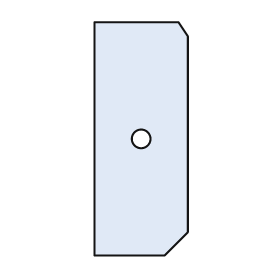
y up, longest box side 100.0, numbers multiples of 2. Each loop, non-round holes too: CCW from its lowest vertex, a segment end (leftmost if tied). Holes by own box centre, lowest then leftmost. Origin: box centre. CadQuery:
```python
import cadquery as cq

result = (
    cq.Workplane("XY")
    .moveTo(-20.0, -50.0)
    .lineTo(10.0, -50.0)
    .lineTo(20.0, -40.0)
    .lineTo(20.0, 44.0)
    .lineTo(16.0, 50.0)
    .lineTo(-20.0, 50.0)
    .close()
    .moveTo(0.0, 0.0)
    .circle(4.0)
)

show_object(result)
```